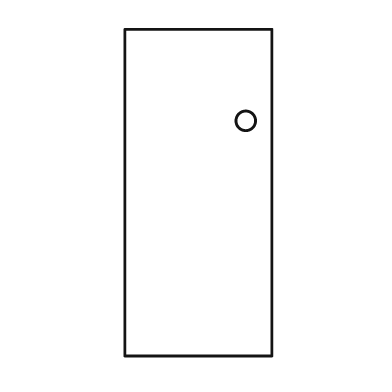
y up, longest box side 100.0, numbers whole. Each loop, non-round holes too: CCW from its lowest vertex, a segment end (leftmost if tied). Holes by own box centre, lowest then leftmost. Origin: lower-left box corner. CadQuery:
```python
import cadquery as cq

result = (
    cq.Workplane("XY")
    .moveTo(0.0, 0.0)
    .lineTo(45.0, 0.0)
    .lineTo(45.0, 100.0)
    .lineTo(0.0, 100.0)
    .close()
    .moveTo(37.0, 72.0)
    .circle(3.0)
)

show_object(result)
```